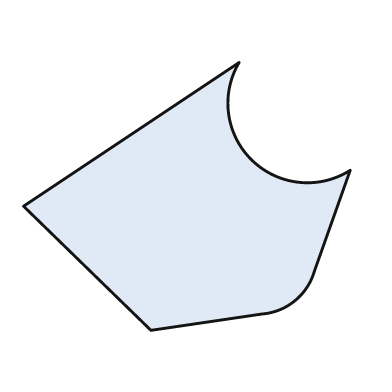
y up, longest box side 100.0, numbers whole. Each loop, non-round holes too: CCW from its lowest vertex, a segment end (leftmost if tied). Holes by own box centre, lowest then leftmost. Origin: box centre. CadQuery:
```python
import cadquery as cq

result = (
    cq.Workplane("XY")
    .moveTo(-11.0, -41.0)
    .lineTo(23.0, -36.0)
    .threePointArc((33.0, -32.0), (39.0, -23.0))
    .lineTo(50.0, 8.0)
    .threePointArc((20.0, 11.0), (16.0, 41.0))
    .lineTo(-50.0, -3.0)
    .close()
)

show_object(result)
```